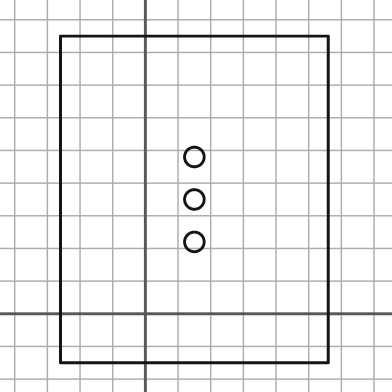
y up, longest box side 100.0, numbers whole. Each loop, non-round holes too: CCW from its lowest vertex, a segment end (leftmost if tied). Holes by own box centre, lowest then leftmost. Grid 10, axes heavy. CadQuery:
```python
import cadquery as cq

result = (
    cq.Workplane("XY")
    .moveTo(-26.0, -15.0)
    .lineTo(56.0, -15.0)
    .lineTo(56.0, 85.0)
    .lineTo(-26.0, 85.0)
    .close()
    .moveTo(15.0, 22.0)
    .circle(3.0)
    .moveTo(15.0, 35.0)
    .circle(3.0)
    .moveTo(15.0, 48.0)
    .circle(3.0)
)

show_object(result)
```